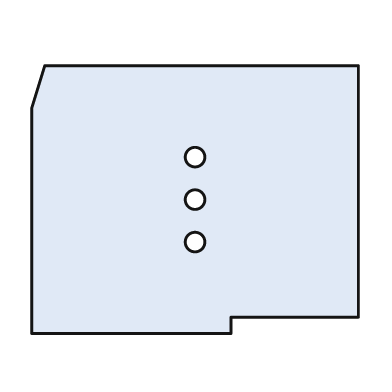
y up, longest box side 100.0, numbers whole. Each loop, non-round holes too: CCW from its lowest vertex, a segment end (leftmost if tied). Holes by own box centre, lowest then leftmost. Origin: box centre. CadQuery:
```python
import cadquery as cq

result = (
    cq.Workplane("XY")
    .moveTo(-50.0, -41.0)
    .lineTo(11.0, -41.0)
    .lineTo(11.0, -36.0)
    .lineTo(50.0, -36.0)
    .lineTo(50.0, 41.0)
    .lineTo(-46.0, 41.0)
    .lineTo(-50.0, 28.0)
    .close()
    .moveTo(0.0, -13.0)
    .circle(3.0)
    .moveTo(0.0, 0.0)
    .circle(3.0)
    .moveTo(0.0, 13.0)
    .circle(3.0)
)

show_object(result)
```